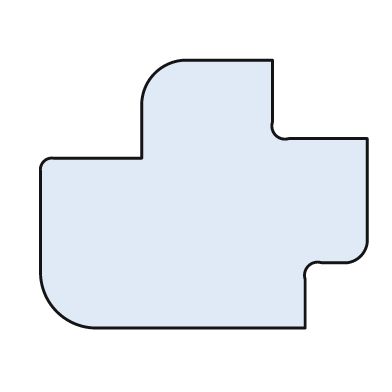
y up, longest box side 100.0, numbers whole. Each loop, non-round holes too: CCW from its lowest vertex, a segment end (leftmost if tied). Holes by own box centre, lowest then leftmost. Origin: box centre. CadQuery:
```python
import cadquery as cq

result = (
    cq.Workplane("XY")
    .moveTo(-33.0, -41.0)
    .lineTo(31.0, -41.0)
    .lineTo(31.0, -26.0)
    .threePointArc((32.0, -22.0), (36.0, -21.0))
    .lineTo(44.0, -21.0)
    .threePointArc((48.0, -19.0), (50.0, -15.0))
    .lineTo(50.0, 17.0)
    .lineTo(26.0, 17.0)
    .threePointArc((22.0, 18.0), (21.0, 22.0))
    .lineTo(21.0, 41.0)
    .lineTo(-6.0, 41.0)
    .threePointArc((-15.0, 37.0), (-19.0, 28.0))
    .lineTo(-19.0, 11.0)
    .lineTo(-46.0, 11.0)
    .threePointArc((-49.0, 10.0), (-50.0, 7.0))
    .lineTo(-50.0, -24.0)
    .threePointArc((-45.0, -36.0), (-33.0, -41.0))
    .close()
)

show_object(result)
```